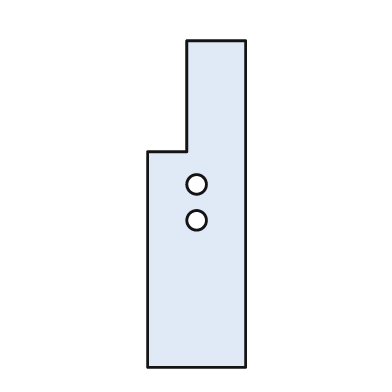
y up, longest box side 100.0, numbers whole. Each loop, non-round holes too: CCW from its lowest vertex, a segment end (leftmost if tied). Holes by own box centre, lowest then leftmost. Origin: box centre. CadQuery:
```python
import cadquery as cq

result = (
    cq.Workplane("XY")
    .moveTo(-15.0, -50.0)
    .lineTo(15.0, -50.0)
    .lineTo(15.0, 50.0)
    .lineTo(-3.0, 50.0)
    .lineTo(-3.0, 16.0)
    .lineTo(-15.0, 16.0)
    .close()
    .moveTo(0.0, -5.0)
    .circle(3.0)
    .moveTo(0.0, 6.0)
    .circle(3.0)
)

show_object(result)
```